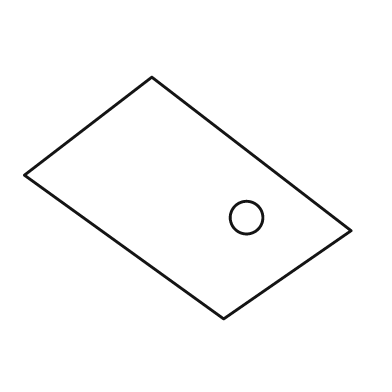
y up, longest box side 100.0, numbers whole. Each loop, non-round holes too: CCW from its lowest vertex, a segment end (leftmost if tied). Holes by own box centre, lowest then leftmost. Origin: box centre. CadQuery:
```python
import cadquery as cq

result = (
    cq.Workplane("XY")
    .moveTo(11.0, -37.0)
    .lineTo(50.0, -10.0)
    .lineTo(-11.0, 37.0)
    .lineTo(-50.0, 7.0)
    .close()
    .moveTo(18.0, -6.0)
    .circle(5.0)
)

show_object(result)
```